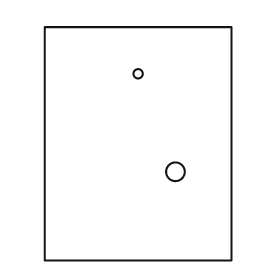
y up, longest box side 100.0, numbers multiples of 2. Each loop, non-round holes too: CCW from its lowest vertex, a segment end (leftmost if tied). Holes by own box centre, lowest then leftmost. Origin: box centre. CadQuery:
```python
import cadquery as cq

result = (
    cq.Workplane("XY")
    .moveTo(-40.0, -50.0)
    .lineTo(40.0, -50.0)
    .lineTo(40.0, 50.0)
    .lineTo(-40.0, 50.0)
    .close()
    .moveTo(16.0, -12.0)
    .circle(4.0)
    .moveTo(0.0, 30.0)
    .circle(2.0)
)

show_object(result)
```